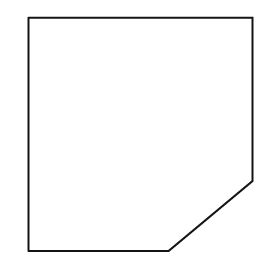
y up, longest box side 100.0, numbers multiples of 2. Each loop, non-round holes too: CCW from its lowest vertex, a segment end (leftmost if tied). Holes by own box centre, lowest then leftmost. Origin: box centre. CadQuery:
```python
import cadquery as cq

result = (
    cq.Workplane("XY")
    .moveTo(-48.0, -50.0)
    .lineTo(12.0, -50.0)
    .lineTo(48.0, -20.0)
    .lineTo(48.0, 50.0)
    .lineTo(-48.0, 50.0)
    .close()
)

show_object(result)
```